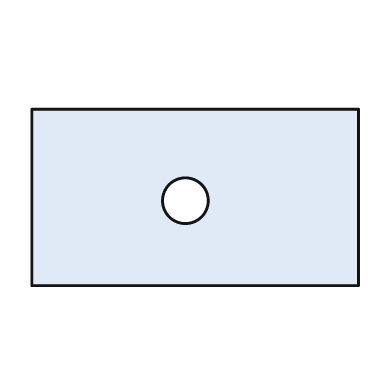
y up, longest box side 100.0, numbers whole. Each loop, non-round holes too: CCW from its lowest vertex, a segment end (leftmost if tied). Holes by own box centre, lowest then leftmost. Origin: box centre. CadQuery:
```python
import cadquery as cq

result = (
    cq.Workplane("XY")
    .moveTo(-50.0, -27.0)
    .lineTo(50.0, -27.0)
    .lineTo(50.0, 27.0)
    .lineTo(-50.0, 27.0)
    .close()
    .moveTo(-3.0, -1.0)
    .circle(7.0)
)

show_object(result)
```